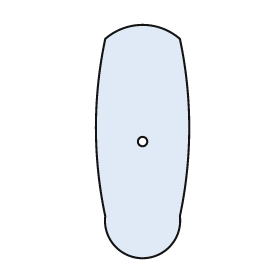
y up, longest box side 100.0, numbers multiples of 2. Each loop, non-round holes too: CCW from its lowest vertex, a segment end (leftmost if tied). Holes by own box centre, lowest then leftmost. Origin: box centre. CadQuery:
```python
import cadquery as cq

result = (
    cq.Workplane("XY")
    .moveTo(-16.0, -32.0)
    .threePointArc((0.0, -50.0), (16.0, -32.0))
    .threePointArc((20.0, 6.0), (16.0, 44.0))
    .threePointArc((0.0, 50.0), (-16.0, 44.0))
    .threePointArc((-20.0, 6.0), (-16.0, -32.0))
    .close()
    .moveTo(0.0, 0.0)
    .circle(2.0)
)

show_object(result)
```